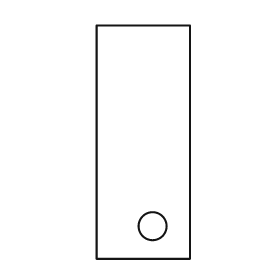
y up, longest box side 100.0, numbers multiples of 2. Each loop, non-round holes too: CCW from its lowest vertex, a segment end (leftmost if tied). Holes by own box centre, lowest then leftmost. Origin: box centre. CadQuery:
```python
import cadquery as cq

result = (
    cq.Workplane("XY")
    .moveTo(-20.0, -50.0)
    .lineTo(20.0, -50.0)
    .lineTo(20.0, 50.0)
    .lineTo(-20.0, 50.0)
    .close()
    .moveTo(4.0, -36.0)
    .circle(6.0)
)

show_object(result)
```